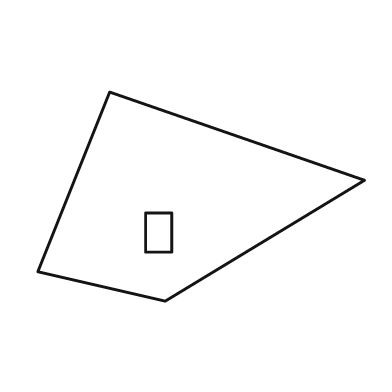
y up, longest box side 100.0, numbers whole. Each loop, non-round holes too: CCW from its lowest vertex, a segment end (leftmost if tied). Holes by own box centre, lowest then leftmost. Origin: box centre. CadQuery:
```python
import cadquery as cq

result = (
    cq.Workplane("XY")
    .moveTo(-11.0, -32.0)
    .lineTo(50.0, 5.0)
    .lineTo(-28.0, 32.0)
    .lineTo(-50.0, -23.0)
    .close()
    .moveTo(-17.0, -17.0)
    .lineTo(-9.0, -17.0)
    .lineTo(-9.0, -5.0)
    .lineTo(-17.0, -5.0)
    .close()
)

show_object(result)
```